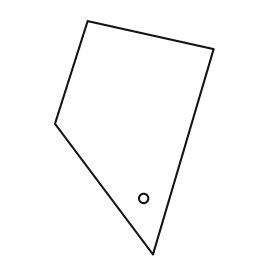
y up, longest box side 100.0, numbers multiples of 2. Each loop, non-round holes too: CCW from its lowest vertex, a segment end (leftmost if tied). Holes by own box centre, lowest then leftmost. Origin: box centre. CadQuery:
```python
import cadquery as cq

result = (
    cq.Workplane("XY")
    .moveTo(8.0, -50.0)
    .lineTo(34.0, 38.0)
    .lineTo(-20.0, 50.0)
    .lineTo(-34.0, 6.0)
    .close()
    .moveTo(4.0, -26.0)
    .circle(2.0)
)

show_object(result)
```